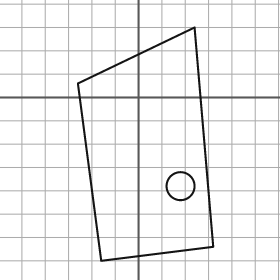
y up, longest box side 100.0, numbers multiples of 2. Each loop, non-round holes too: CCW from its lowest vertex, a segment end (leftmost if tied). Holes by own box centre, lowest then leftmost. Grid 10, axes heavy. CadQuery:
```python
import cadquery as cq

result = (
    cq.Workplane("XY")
    .moveTo(-16.0, -70.0)
    .lineTo(32.0, -64.0)
    .lineTo(24.0, 30.0)
    .lineTo(-26.0, 6.0)
    .close()
    .moveTo(18.0, -38.0)
    .circle(6.0)
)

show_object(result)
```